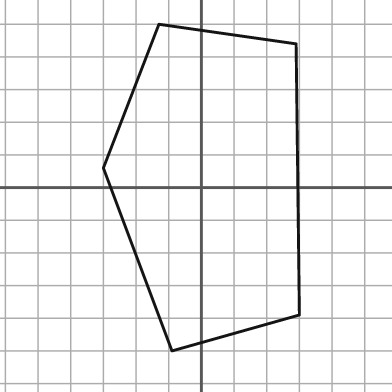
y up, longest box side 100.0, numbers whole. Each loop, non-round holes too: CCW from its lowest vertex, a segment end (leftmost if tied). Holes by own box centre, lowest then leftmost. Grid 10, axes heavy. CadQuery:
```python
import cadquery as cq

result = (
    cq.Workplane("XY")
    .moveTo(-9.0, -50.0)
    .lineTo(30.0, -39.0)
    .lineTo(29.0, 44.0)
    .lineTo(-13.0, 50.0)
    .lineTo(-30.0, 6.0)
    .close()
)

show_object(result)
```